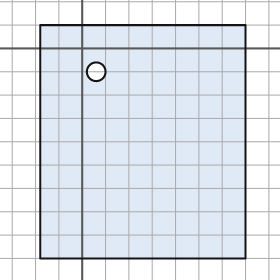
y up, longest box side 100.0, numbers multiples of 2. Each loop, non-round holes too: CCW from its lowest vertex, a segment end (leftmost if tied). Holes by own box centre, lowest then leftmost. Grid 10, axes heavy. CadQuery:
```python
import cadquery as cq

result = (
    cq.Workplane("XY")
    .moveTo(-18.0, -90.0)
    .lineTo(70.0, -90.0)
    .lineTo(70.0, 10.0)
    .lineTo(-18.0, 10.0)
    .close()
    .moveTo(6.0, -10.0)
    .circle(4.0)
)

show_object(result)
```